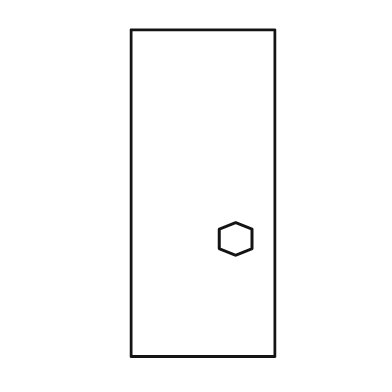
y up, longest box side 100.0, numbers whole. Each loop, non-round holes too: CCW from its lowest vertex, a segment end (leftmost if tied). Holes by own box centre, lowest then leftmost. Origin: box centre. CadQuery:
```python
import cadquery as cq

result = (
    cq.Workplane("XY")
    .moveTo(-22.0, -50.0)
    .lineTo(22.0, -50.0)
    .lineTo(22.0, 50.0)
    .lineTo(-22.0, 50.0)
    .close()
    .moveTo(10.0, -19.0)
    .lineTo(15.0, -17.0)
    .lineTo(15.0, -11.0)
    .lineTo(10.0, -9.0)
    .lineTo(5.0, -11.0)
    .lineTo(5.0, -17.0)
    .close()
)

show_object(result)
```